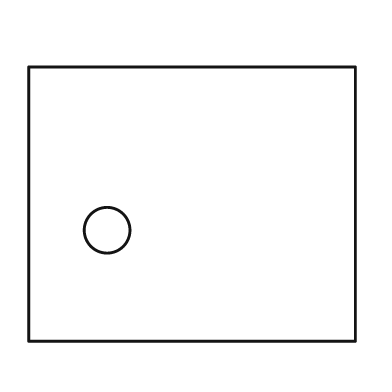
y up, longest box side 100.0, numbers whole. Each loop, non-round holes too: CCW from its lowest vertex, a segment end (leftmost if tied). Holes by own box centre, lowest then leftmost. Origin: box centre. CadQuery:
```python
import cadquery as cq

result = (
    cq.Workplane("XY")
    .moveTo(-50.0, -42.0)
    .lineTo(50.0, -42.0)
    .lineTo(50.0, 42.0)
    .lineTo(-50.0, 42.0)
    .close()
    .moveTo(-26.0, -8.0)
    .circle(7.0)
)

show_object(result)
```